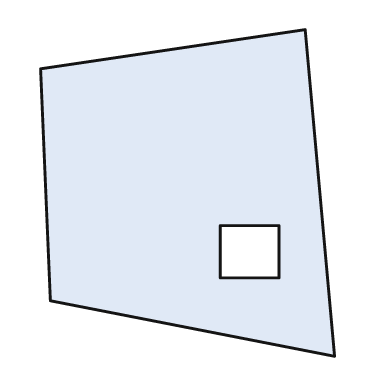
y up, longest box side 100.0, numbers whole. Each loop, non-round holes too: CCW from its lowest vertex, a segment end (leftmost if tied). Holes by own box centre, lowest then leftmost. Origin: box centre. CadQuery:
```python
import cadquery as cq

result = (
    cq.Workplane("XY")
    .moveTo(45.0, -50.0)
    .lineTo(36.0, 50.0)
    .lineTo(-45.0, 38.0)
    .lineTo(-42.0, -33.0)
    .close()
    .moveTo(10.0, -26.0)
    .lineTo(28.0, -26.0)
    .lineTo(28.0, -10.0)
    .lineTo(10.0, -10.0)
    .close()
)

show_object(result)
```